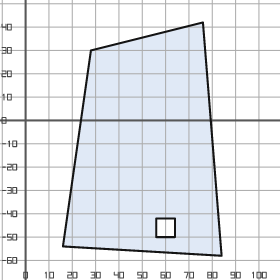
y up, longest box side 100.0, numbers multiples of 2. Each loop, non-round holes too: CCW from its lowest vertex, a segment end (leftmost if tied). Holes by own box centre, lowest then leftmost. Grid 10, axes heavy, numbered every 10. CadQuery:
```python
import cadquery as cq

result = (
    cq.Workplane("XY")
    .moveTo(84.0, -58.0)
    .lineTo(76.0, 42.0)
    .lineTo(28.0, 30.0)
    .lineTo(16.0, -54.0)
    .close()
    .moveTo(56.0, -50.0)
    .lineTo(64.0, -50.0)
    .lineTo(64.0, -42.0)
    .lineTo(56.0, -42.0)
    .close()
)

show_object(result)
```